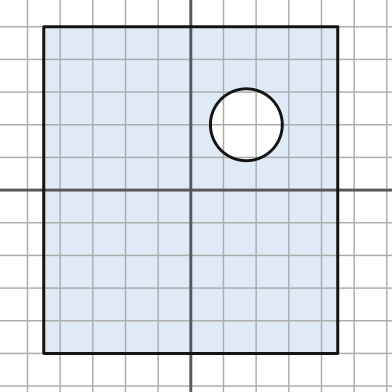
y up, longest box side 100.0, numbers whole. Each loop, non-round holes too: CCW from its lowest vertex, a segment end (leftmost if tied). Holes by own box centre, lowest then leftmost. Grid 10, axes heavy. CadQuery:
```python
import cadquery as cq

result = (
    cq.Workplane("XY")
    .moveTo(-45.0, -50.0)
    .lineTo(45.0, -50.0)
    .lineTo(45.0, 50.0)
    .lineTo(-45.0, 50.0)
    .close()
    .moveTo(17.0, 20.0)
    .circle(11.0)
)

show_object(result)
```